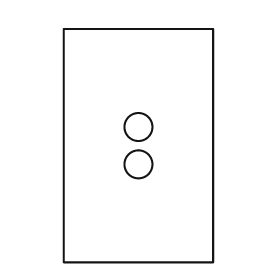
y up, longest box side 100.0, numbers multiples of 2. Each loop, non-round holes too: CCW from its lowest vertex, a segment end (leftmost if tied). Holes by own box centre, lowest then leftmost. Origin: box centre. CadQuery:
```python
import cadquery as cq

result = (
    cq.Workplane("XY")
    .moveTo(-32.0, -50.0)
    .lineTo(32.0, -50.0)
    .lineTo(32.0, 50.0)
    .lineTo(-32.0, 50.0)
    .close()
    .moveTo(0.0, -8.0)
    .circle(6.0)
    .moveTo(0.0, 8.0)
    .circle(6.0)
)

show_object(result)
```